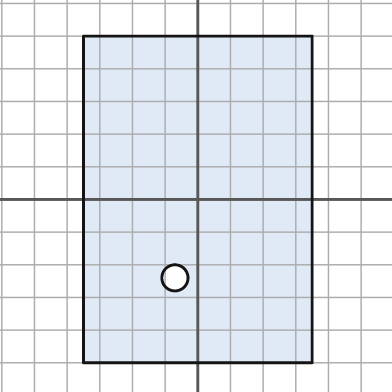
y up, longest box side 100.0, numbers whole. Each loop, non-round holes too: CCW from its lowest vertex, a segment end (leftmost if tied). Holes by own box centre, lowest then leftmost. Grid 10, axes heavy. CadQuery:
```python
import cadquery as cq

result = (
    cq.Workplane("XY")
    .moveTo(-35.0, -50.0)
    .lineTo(35.0, -50.0)
    .lineTo(35.0, 50.0)
    .lineTo(-35.0, 50.0)
    .close()
    .moveTo(-7.0, -24.0)
    .circle(4.0)
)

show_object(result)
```